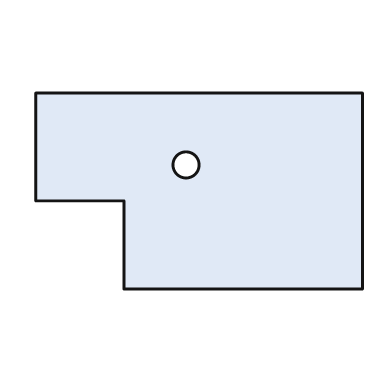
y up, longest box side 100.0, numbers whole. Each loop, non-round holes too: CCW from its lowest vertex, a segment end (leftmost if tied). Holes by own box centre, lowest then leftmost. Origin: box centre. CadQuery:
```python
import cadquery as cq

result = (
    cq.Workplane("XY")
    .moveTo(-23.0, -30.0)
    .lineTo(50.0, -30.0)
    .lineTo(50.0, 30.0)
    .lineTo(-50.0, 30.0)
    .lineTo(-50.0, -3.0)
    .lineTo(-23.0, -3.0)
    .close()
    .moveTo(-4.0, 8.0)
    .circle(4.0)
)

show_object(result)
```